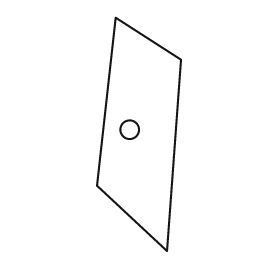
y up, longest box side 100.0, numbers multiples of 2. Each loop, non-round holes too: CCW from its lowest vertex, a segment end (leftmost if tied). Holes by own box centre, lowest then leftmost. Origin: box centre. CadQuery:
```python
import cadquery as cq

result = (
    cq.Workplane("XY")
    .moveTo(12.0, -50.0)
    .lineTo(18.0, 32.0)
    .lineTo(-10.0, 50.0)
    .lineTo(-18.0, -22.0)
    .close()
    .moveTo(-4.0, 2.0)
    .circle(4.0)
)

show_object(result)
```